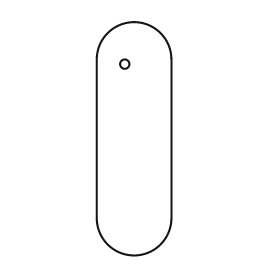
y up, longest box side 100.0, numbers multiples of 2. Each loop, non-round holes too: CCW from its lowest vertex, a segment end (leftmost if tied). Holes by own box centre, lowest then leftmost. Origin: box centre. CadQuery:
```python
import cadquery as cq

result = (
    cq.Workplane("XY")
    .moveTo(-16.0, -34.0)
    .threePointArc((0.0, -50.0), (16.0, -34.0))
    .lineTo(16.0, 34.0)
    .threePointArc((0.0, 50.0), (-16.0, 34.0))
    .close()
    .moveTo(-4.0, 32.0)
    .circle(2.0)
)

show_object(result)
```